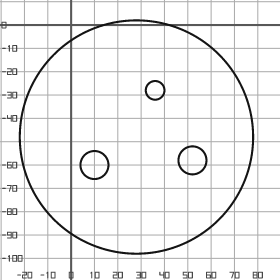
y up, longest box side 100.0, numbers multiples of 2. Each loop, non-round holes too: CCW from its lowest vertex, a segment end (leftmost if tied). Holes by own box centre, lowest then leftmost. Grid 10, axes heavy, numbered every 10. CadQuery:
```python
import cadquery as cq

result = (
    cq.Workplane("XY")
    .moveTo(28.0, -48.0)
    .circle(50.0)
    .moveTo(10.0, -60.0)
    .circle(6.0)
    .moveTo(52.0, -58.0)
    .circle(6.0)
    .moveTo(36.0, -28.0)
    .circle(4.0)
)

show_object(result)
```